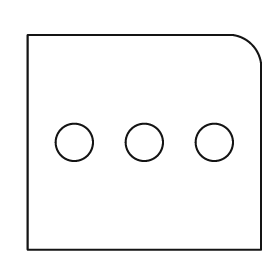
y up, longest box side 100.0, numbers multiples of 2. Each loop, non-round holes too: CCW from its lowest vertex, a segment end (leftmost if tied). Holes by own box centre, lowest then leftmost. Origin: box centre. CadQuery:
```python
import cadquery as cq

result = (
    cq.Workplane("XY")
    .moveTo(-50.0, -46.0)
    .lineTo(50.0, -46.0)
    .lineTo(50.0, 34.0)
    .threePointArc((46.0, 42.0), (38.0, 46.0))
    .lineTo(-50.0, 46.0)
    .close()
    .moveTo(-30.0, 0.0)
    .circle(8.0)
    .moveTo(0.0, 0.0)
    .circle(8.0)
    .moveTo(30.0, 0.0)
    .circle(8.0)
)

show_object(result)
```